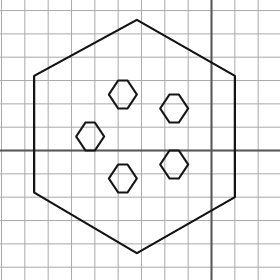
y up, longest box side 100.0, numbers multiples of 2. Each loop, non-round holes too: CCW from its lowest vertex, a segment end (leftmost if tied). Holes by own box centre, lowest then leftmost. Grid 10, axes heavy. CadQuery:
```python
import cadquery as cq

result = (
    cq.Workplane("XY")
    .moveTo(-32.0, -44.0)
    .lineTo(10.0, -20.0)
    .lineTo(10.0, 32.0)
    .lineTo(-32.0, 56.0)
    .lineTo(-76.0, 32.0)
    .lineTo(-76.0, -18.0)
    .close()
    .moveTo(-40.0, -18.0)
    .lineTo(-36.0, -18.0)
    .lineTo(-32.0, -12.0)
    .lineTo(-36.0, -6.0)
    .lineTo(-40.0, -6.0)
    .lineTo(-44.0, -12.0)
    .close()
    .moveTo(-18.0, -12.0)
    .lineTo(-14.0, -12.0)
    .lineTo(-10.0, -6.0)
    .lineTo(-14.0, 0.0)
    .lineTo(-18.0, 0.0)
    .lineTo(-22.0, -6.0)
    .close()
    .moveTo(-54.0, 0.0)
    .lineTo(-50.0, 0.0)
    .lineTo(-46.0, 6.0)
    .lineTo(-50.0, 12.0)
    .lineTo(-54.0, 12.0)
    .lineTo(-58.0, 6.0)
    .close()
    .moveTo(-18.0, 12.0)
    .lineTo(-14.0, 12.0)
    .lineTo(-10.0, 18.0)
    .lineTo(-14.0, 24.0)
    .lineTo(-18.0, 24.0)
    .lineTo(-22.0, 18.0)
    .close()
    .moveTo(-40.0, 18.0)
    .lineTo(-36.0, 18.0)
    .lineTo(-32.0, 24.0)
    .lineTo(-36.0, 30.0)
    .lineTo(-40.0, 30.0)
    .lineTo(-44.0, 24.0)
    .close()
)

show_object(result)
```